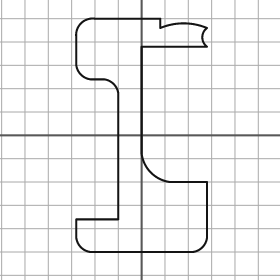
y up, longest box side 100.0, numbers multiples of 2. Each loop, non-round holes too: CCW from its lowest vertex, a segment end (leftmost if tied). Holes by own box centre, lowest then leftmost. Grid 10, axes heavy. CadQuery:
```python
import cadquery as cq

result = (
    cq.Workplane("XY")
    .moveTo(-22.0, -50.0)
    .lineTo(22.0, -50.0)
    .threePointArc((26.0, -48.0), (28.0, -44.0))
    .lineTo(28.0, -20.0)
    .lineTo(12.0, -20.0)
    .threePointArc((4.0, -16.0), (0.0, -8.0))
    .lineTo(0.0, 38.0)
    .lineTo(28.0, 38.0)
    .threePointArc((26.0, 42.0), (28.0, 46.0))
    .threePointArc((18.0, 48.0), (8.0, 46.0))
    .lineTo(8.0, 50.0)
    .lineTo(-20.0, 50.0)
    .threePointArc((-26.0, 48.0), (-28.0, 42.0))
    .lineTo(-28.0, 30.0)
    .threePointArc((-26.0, 26.0), (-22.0, 24.0))
    .lineTo(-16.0, 24.0)
    .threePointArc((-12.0, 22.0), (-10.0, 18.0))
    .lineTo(-10.0, -36.0)
    .lineTo(-28.0, -36.0)
    .lineTo(-28.0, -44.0)
    .threePointArc((-26.0, -48.0), (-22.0, -50.0))
    .close()
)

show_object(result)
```